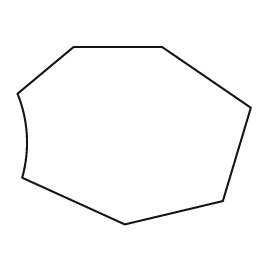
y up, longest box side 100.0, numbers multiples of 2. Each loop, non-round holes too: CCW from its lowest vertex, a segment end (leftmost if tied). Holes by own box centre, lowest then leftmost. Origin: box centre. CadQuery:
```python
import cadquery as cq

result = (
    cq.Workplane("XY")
    .moveTo(-4.0, -38.0)
    .lineTo(38.0, -28.0)
    .lineTo(50.0, 12.0)
    .lineTo(12.0, 38.0)
    .lineTo(-26.0, 38.0)
    .lineTo(-50.0, 18.0)
    .threePointArc((-46.0, 0.0), (-48.0, -18.0))
    .close()
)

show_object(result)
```